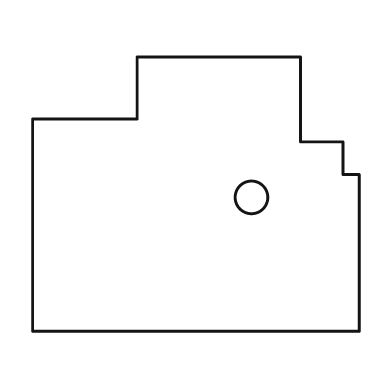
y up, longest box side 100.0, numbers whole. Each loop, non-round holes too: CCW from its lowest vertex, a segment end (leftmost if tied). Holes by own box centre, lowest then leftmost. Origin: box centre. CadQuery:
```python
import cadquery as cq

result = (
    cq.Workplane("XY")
    .moveTo(-50.0, -42.0)
    .lineTo(50.0, -42.0)
    .lineTo(50.0, 6.0)
    .lineTo(45.0, 6.0)
    .lineTo(45.0, 16.0)
    .lineTo(32.0, 16.0)
    .lineTo(32.0, 42.0)
    .lineTo(-18.0, 42.0)
    .lineTo(-18.0, 23.0)
    .lineTo(-50.0, 23.0)
    .close()
    .moveTo(17.0, -1.0)
    .circle(5.0)
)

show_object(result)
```